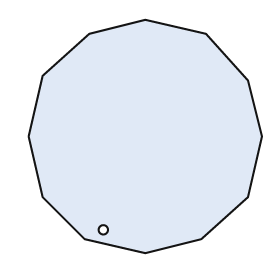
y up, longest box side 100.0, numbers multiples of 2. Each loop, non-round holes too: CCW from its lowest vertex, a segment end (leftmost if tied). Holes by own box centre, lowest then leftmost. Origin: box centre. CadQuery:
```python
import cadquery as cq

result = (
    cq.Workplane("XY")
    .moveTo(0.0, -50.0)
    .lineTo(24.0, -44.0)
    .lineTo(44.0, -26.0)
    .lineTo(50.0, 0.0)
    .lineTo(44.0, 24.0)
    .lineTo(26.0, 44.0)
    .lineTo(0.0, 50.0)
    .lineTo(-24.0, 44.0)
    .lineTo(-44.0, 26.0)
    .lineTo(-50.0, 0.0)
    .lineTo(-44.0, -26.0)
    .lineTo(-26.0, -44.0)
    .close()
    .moveTo(-18.0, -40.0)
    .circle(2.0)
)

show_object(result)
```